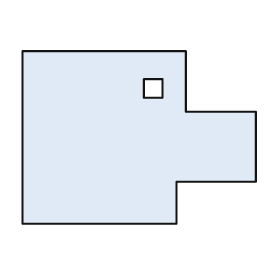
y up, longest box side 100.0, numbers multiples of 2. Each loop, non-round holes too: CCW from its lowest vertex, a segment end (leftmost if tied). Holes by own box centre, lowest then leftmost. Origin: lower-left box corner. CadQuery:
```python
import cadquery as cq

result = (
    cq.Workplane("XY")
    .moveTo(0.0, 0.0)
    .lineTo(66.0, 0.0)
    .lineTo(66.0, 18.0)
    .lineTo(100.0, 18.0)
    .lineTo(100.0, 48.0)
    .lineTo(70.0, 48.0)
    .lineTo(70.0, 74.0)
    .lineTo(0.0, 74.0)
    .close()
    .moveTo(52.0, 54.0)
    .lineTo(60.0, 54.0)
    .lineTo(60.0, 62.0)
    .lineTo(52.0, 62.0)
    .close()
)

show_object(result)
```